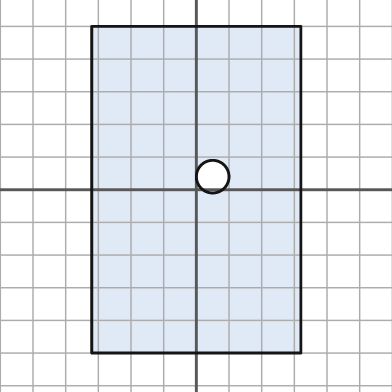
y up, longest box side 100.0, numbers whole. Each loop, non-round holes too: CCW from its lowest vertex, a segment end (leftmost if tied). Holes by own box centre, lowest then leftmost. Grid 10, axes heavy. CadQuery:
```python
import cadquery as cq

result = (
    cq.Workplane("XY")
    .moveTo(-32.0, -50.0)
    .lineTo(32.0, -50.0)
    .lineTo(32.0, 50.0)
    .lineTo(-32.0, 50.0)
    .close()
    .moveTo(5.0, 4.0)
    .circle(5.0)
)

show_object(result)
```